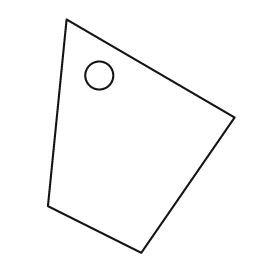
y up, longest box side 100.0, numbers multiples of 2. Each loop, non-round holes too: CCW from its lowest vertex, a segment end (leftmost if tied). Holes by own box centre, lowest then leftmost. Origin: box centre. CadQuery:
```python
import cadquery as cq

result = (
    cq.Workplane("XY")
    .moveTo(0.0, -50.0)
    .lineTo(40.0, 8.0)
    .lineTo(-32.0, 50.0)
    .lineTo(-40.0, -30.0)
    .close()
    .moveTo(-18.0, 26.0)
    .circle(6.0)
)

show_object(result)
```